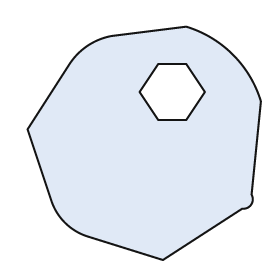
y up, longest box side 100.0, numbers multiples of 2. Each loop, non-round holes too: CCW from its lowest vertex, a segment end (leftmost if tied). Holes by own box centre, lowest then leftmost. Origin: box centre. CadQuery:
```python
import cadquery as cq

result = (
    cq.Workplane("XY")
    .moveTo(8.0, -50.0)
    .lineTo(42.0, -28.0)
    .threePointArc((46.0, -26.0), (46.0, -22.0))
    .lineTo(50.0, 18.0)
    .threePointArc((38.0, 38.0), (18.0, 50.0))
    .lineTo(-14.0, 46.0)
    .threePointArc((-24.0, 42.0), (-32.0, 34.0))
    .lineTo(-50.0, 6.0)
    .lineTo(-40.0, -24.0)
    .threePointArc((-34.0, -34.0), (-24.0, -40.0))
    .close()
    .moveTo(6.0, 10.0)
    .lineTo(18.0, 10.0)
    .lineTo(26.0, 22.0)
    .lineTo(18.0, 34.0)
    .lineTo(6.0, 34.0)
    .lineTo(-2.0, 22.0)
    .close()
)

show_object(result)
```